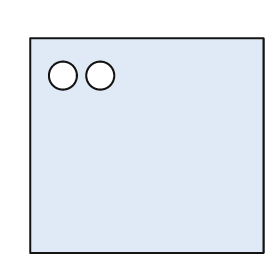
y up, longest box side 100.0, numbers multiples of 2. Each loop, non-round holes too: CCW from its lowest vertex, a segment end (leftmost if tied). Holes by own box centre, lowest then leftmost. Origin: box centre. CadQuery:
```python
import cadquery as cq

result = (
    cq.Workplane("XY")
    .moveTo(-50.0, -46.0)
    .lineTo(50.0, -46.0)
    .lineTo(50.0, 46.0)
    .lineTo(-50.0, 46.0)
    .close()
    .moveTo(-36.0, 30.0)
    .circle(6.0)
    .moveTo(-20.0, 30.0)
    .circle(6.0)
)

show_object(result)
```